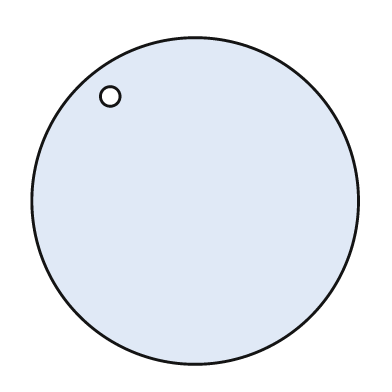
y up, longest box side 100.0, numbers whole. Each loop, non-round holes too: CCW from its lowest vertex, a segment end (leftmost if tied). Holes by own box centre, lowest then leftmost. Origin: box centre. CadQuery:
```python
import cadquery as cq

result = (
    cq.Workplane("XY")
    .moveTo(0.0, 0.0)
    .circle(50.0)
    .moveTo(-26.0, 32.0)
    .circle(3.0)
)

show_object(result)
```